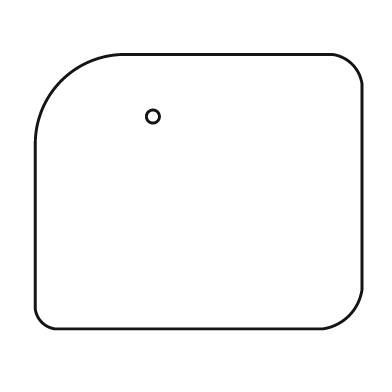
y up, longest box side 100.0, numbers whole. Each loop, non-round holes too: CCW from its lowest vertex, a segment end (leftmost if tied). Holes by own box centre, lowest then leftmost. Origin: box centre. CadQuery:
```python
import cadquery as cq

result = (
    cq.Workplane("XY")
    .moveTo(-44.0, -42.0)
    .lineTo(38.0, -42.0)
    .threePointArc((46.0, -38.0), (50.0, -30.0))
    .lineTo(50.0, 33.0)
    .threePointArc((47.0, 39.0), (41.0, 42.0))
    .lineTo(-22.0, 42.0)
    .threePointArc((-42.0, 34.0), (-50.0, 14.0))
    .lineTo(-50.0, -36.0)
    .threePointArc((-48.0, -40.0), (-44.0, -42.0))
    .close()
    .moveTo(-14.0, 23.0)
    .circle(2.0)
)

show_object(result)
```